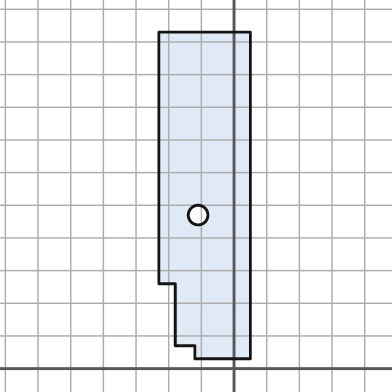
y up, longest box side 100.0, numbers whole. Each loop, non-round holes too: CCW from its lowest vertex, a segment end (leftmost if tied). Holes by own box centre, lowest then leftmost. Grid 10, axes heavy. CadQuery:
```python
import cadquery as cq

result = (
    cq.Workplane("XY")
    .moveTo(-12.0, 3.0)
    .lineTo(5.0, 3.0)
    .lineTo(5.0, 103.0)
    .lineTo(-23.0, 103.0)
    .lineTo(-23.0, 26.0)
    .lineTo(-18.0, 26.0)
    .lineTo(-18.0, 7.0)
    .lineTo(-12.0, 7.0)
    .close()
    .moveTo(-11.0, 47.0)
    .circle(3.0)
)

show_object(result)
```